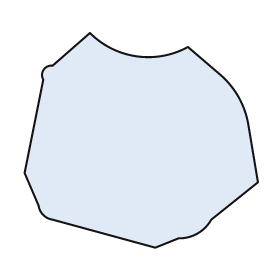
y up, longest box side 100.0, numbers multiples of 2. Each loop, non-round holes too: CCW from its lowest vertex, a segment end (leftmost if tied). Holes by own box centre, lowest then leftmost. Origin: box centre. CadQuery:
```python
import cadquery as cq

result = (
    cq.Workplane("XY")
    .moveTo(6.0, -46.0)
    .lineTo(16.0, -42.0)
    .threePointArc((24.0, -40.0), (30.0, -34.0))
    .lineTo(50.0, -18.0)
    .lineTo(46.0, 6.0)
    .threePointArc((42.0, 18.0), (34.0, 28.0))
    .lineTo(20.0, 40.0)
    .threePointArc((-2.0, 36.0), (-22.0, 46.0))
    .lineTo(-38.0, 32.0)
    .threePointArc((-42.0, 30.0), (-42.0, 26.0))
    .lineTo(-50.0, -14.0)
    .lineTo(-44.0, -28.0)
    .threePointArc((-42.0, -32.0), (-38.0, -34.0))
    .close()
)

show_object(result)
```